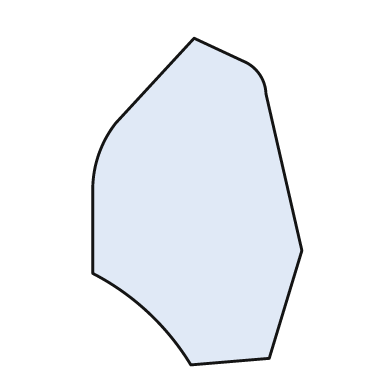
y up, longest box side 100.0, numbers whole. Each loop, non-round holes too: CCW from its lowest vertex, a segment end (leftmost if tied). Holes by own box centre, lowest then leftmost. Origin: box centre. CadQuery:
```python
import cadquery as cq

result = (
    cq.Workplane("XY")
    .moveTo(-2.0, -50.0)
    .lineTo(22.0, -48.0)
    .lineTo(32.0, -15.0)
    .lineTo(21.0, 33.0)
    .threePointArc((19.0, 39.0), (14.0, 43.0))
    .lineTo(-1.0, 50.0)
    .lineTo(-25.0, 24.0)
    .threePointArc((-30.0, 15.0), (-32.0, 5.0))
    .lineTo(-32.0, -22.0)
    .threePointArc((-15.0, -34.0), (-2.0, -50.0))
    .close()
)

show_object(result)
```